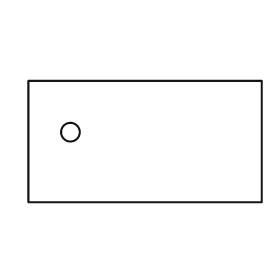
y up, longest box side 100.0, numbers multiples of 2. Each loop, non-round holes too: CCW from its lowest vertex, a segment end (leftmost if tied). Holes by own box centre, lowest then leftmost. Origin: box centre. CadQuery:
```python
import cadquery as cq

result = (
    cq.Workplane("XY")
    .moveTo(-50.0, -26.0)
    .lineTo(50.0, -26.0)
    .lineTo(50.0, 26.0)
    .lineTo(-50.0, 26.0)
    .close()
    .moveTo(-32.0, 4.0)
    .circle(4.0)
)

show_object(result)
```